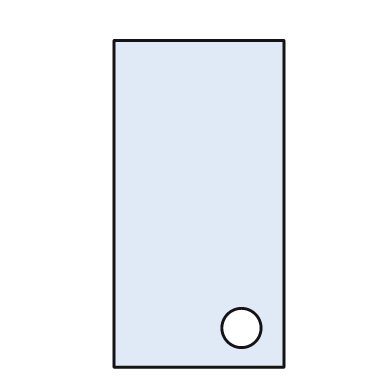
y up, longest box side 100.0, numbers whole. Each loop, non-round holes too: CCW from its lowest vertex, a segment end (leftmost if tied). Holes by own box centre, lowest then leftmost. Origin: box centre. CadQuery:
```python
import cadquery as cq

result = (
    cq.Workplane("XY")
    .moveTo(-26.0, -50.0)
    .lineTo(26.0, -50.0)
    .lineTo(26.0, 50.0)
    .lineTo(-26.0, 50.0)
    .close()
    .moveTo(13.0, -38.0)
    .circle(6.0)
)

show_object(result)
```